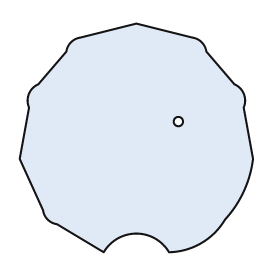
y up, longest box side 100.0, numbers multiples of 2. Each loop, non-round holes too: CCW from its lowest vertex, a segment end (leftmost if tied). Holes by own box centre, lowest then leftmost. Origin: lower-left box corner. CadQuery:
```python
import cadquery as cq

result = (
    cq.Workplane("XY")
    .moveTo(36.0, 0.0)
    .threePointArc((50.0, 8.0), (64.0, 0.0))
    .threePointArc((78.0, 4.0), (88.0, 14.0))
    .threePointArc((96.0, 26.0), (100.0, 40.0))
    .lineTo(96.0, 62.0)
    .threePointArc((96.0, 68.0), (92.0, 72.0))
    .lineTo(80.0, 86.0)
    .threePointArc((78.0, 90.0), (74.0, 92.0))
    .lineTo(50.0, 98.0)
    .lineTo(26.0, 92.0)
    .threePointArc((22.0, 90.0), (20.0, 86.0))
    .lineTo(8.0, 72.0)
    .threePointArc((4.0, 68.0), (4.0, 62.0))
    .lineTo(0.0, 40.0)
    .lineTo(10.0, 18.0)
    .threePointArc((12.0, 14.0), (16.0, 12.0))
    .close()
    .moveTo(68.0, 56.0)
    .circle(2.0)
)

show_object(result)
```